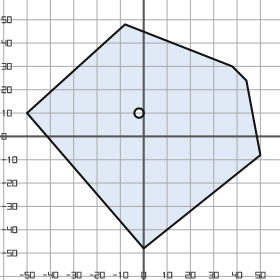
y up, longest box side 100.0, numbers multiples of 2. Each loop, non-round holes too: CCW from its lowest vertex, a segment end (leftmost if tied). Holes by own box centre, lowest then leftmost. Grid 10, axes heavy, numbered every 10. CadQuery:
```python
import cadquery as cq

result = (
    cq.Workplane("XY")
    .moveTo(0.0, -48.0)
    .lineTo(50.0, -8.0)
    .lineTo(44.0, 24.0)
    .lineTo(38.0, 30.0)
    .lineTo(-8.0, 48.0)
    .lineTo(-50.0, 10.0)
    .close()
    .moveTo(-2.0, 10.0)
    .circle(2.0)
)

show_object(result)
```